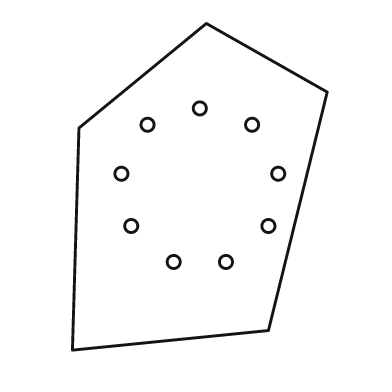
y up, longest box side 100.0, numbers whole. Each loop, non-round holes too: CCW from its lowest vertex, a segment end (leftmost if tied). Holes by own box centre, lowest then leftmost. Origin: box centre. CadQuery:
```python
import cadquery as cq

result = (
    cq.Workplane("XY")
    .moveTo(-39.0, -50.0)
    .lineTo(21.0, -44.0)
    .lineTo(39.0, 29.0)
    .lineTo(2.0, 50.0)
    .lineTo(-37.0, 18.0)
    .close()
    .moveTo(-8.0, -23.0)
    .circle(2.0)
    .moveTo(8.0, -23.0)
    .circle(2.0)
    .moveTo(-21.0, -12.0)
    .circle(2.0)
    .moveTo(21.0, -12.0)
    .circle(2.0)
    .moveTo(-24.0, 4.0)
    .circle(2.0)
    .moveTo(24.0, 4.0)
    .circle(2.0)
    .moveTo(-16.0, 19.0)
    .circle(2.0)
    .moveTo(16.0, 19.0)
    .circle(2.0)
    .moveTo(0.0, 24.0)
    .circle(2.0)
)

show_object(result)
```